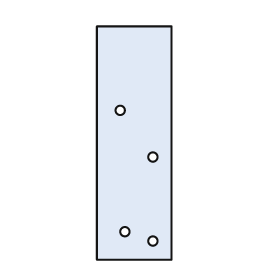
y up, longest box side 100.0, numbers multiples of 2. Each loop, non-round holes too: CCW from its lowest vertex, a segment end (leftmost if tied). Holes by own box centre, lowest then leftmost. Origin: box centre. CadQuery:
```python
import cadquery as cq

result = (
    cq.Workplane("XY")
    .moveTo(-16.0, -50.0)
    .lineTo(16.0, -50.0)
    .lineTo(16.0, 50.0)
    .lineTo(-16.0, 50.0)
    .close()
    .moveTo(8.0, -42.0)
    .circle(2.0)
    .moveTo(-4.0, -38.0)
    .circle(2.0)
    .moveTo(8.0, -6.0)
    .circle(2.0)
    .moveTo(-6.0, 14.0)
    .circle(2.0)
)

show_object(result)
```